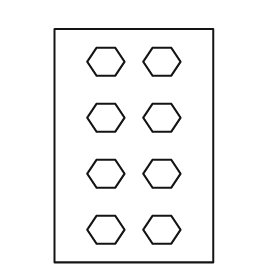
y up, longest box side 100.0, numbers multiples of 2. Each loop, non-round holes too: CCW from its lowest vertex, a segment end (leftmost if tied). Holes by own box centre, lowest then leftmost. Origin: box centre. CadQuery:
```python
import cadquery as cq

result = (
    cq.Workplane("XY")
    .moveTo(-34.0, -50.0)
    .lineTo(34.0, -50.0)
    .lineTo(34.0, 50.0)
    .lineTo(-34.0, 50.0)
    .close()
    .moveTo(-16.0, -42.0)
    .lineTo(-8.0, -42.0)
    .lineTo(-4.0, -36.0)
    .lineTo(-8.0, -30.0)
    .lineTo(-16.0, -30.0)
    .lineTo(-20.0, -36.0)
    .close()
    .moveTo(8.0, -42.0)
    .lineTo(16.0, -42.0)
    .lineTo(20.0, -36.0)
    .lineTo(16.0, -30.0)
    .lineTo(8.0, -30.0)
    .lineTo(4.0, -36.0)
    .close()
    .moveTo(-16.0, -18.0)
    .lineTo(-8.0, -18.0)
    .lineTo(-4.0, -12.0)
    .lineTo(-8.0, -6.0)
    .lineTo(-16.0, -6.0)
    .lineTo(-20.0, -12.0)
    .close()
    .moveTo(8.0, -18.0)
    .lineTo(16.0, -18.0)
    .lineTo(20.0, -12.0)
    .lineTo(16.0, -6.0)
    .lineTo(8.0, -6.0)
    .lineTo(4.0, -12.0)
    .close()
    .moveTo(-16.0, 6.0)
    .lineTo(-8.0, 6.0)
    .lineTo(-4.0, 12.0)
    .lineTo(-8.0, 18.0)
    .lineTo(-16.0, 18.0)
    .lineTo(-20.0, 12.0)
    .close()
    .moveTo(8.0, 6.0)
    .lineTo(16.0, 6.0)
    .lineTo(20.0, 12.0)
    .lineTo(16.0, 18.0)
    .lineTo(8.0, 18.0)
    .lineTo(4.0, 12.0)
    .close()
    .moveTo(-16.0, 30.0)
    .lineTo(-8.0, 30.0)
    .lineTo(-4.0, 36.0)
    .lineTo(-8.0, 42.0)
    .lineTo(-16.0, 42.0)
    .lineTo(-20.0, 36.0)
    .close()
    .moveTo(8.0, 30.0)
    .lineTo(16.0, 30.0)
    .lineTo(20.0, 36.0)
    .lineTo(16.0, 42.0)
    .lineTo(8.0, 42.0)
    .lineTo(4.0, 36.0)
    .close()
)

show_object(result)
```